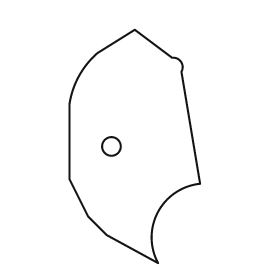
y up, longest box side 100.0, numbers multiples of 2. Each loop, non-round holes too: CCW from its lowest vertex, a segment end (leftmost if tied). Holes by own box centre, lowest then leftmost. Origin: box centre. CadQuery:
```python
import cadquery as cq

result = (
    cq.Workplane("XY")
    .moveTo(10.0, -50.0)
    .threePointArc((10.0, -28.0), (28.0, -16.0))
    .lineTo(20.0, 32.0)
    .threePointArc((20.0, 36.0), (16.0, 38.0))
    .lineTo(0.0, 50.0)
    .lineTo(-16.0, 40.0)
    .threePointArc((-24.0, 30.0), (-28.0, 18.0))
    .lineTo(-28.0, -14.0)
    .lineTo(-20.0, -30.0)
    .lineTo(-12.0, -38.0)
    .close()
    .moveTo(-10.0, 0.0)
    .circle(4.0)
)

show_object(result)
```